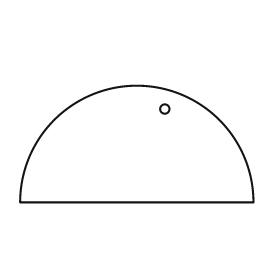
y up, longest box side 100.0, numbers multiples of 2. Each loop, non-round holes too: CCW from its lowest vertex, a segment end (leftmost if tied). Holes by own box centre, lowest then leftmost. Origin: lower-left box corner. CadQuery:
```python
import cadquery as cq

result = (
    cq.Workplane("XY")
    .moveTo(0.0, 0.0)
    .lineTo(100.0, 0.0)
    .threePointArc((50.0, 50.0), (0.0, 0.0))
    .close()
    .moveTo(62.0, 40.0)
    .circle(2.0)
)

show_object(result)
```